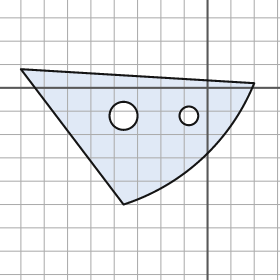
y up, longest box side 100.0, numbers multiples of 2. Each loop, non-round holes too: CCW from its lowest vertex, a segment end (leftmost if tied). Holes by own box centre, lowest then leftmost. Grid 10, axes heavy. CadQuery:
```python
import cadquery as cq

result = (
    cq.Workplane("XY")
    .moveTo(-36.0, -50.0)
    .threePointArc((-2.0, -30.0), (20.0, 2.0))
    .lineTo(-80.0, 8.0)
    .close()
    .moveTo(-36.0, -12.0)
    .circle(6.0)
    .moveTo(-8.0, -12.0)
    .circle(4.0)
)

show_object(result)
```